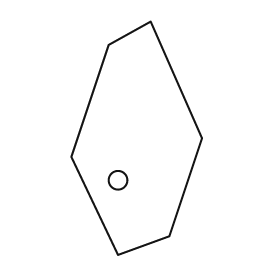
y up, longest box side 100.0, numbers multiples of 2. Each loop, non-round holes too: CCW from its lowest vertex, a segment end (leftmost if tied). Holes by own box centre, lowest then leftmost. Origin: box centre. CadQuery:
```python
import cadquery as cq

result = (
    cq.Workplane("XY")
    .moveTo(-8.0, -50.0)
    .lineTo(14.0, -42.0)
    .lineTo(28.0, 0.0)
    .lineTo(6.0, 50.0)
    .lineTo(-12.0, 40.0)
    .lineTo(-28.0, -8.0)
    .close()
    .moveTo(-8.0, -18.0)
    .circle(4.0)
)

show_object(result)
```